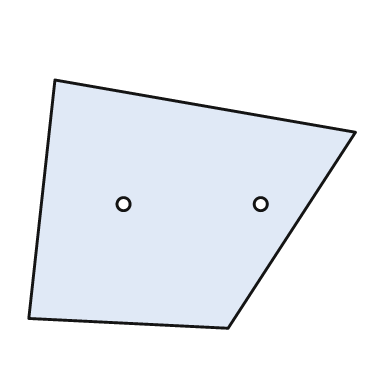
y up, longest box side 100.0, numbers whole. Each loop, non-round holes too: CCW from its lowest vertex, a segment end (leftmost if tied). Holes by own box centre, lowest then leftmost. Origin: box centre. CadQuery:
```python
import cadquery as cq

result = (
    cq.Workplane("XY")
    .moveTo(11.0, -38.0)
    .lineTo(50.0, 22.0)
    .lineTo(-42.0, 38.0)
    .lineTo(-50.0, -35.0)
    .close()
    .moveTo(-21.0, 0.0)
    .circle(2.0)
    .moveTo(21.0, 0.0)
    .circle(2.0)
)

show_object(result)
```